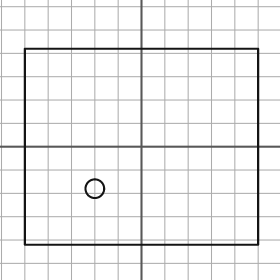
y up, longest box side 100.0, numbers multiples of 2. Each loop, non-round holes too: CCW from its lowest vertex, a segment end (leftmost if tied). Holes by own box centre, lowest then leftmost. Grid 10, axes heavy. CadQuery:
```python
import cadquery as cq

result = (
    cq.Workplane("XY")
    .moveTo(-50.0, -42.0)
    .lineTo(50.0, -42.0)
    .lineTo(50.0, 42.0)
    .lineTo(-50.0, 42.0)
    .close()
    .moveTo(-20.0, -18.0)
    .circle(4.0)
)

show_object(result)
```